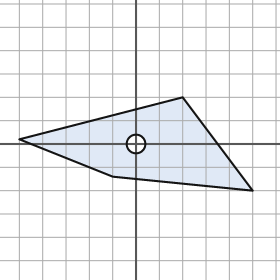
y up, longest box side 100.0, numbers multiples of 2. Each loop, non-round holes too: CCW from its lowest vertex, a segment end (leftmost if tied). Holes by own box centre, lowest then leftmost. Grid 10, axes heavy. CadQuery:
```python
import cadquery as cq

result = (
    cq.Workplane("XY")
    .moveTo(50.0, -20.0)
    .lineTo(20.0, 20.0)
    .lineTo(-50.0, 2.0)
    .lineTo(-10.0, -14.0)
    .close()
    .moveTo(0.0, 0.0)
    .circle(4.0)
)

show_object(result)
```